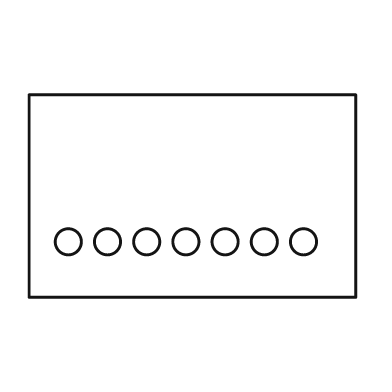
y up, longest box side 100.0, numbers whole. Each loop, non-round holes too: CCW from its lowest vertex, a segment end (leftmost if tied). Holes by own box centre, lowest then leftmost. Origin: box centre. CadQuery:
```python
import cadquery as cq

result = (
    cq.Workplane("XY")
    .moveTo(-50.0, -31.0)
    .lineTo(50.0, -31.0)
    .lineTo(50.0, 31.0)
    .lineTo(-50.0, 31.0)
    .close()
    .moveTo(-38.0, -14.0)
    .circle(4.0)
    .moveTo(-26.0, -14.0)
    .circle(4.0)
    .moveTo(-14.0, -14.0)
    .circle(4.0)
    .moveTo(-2.0, -14.0)
    .circle(4.0)
    .moveTo(10.0, -14.0)
    .circle(4.0)
    .moveTo(22.0, -14.0)
    .circle(4.0)
    .moveTo(34.0, -14.0)
    .circle(4.0)
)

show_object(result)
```